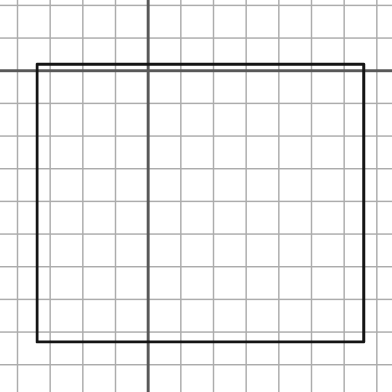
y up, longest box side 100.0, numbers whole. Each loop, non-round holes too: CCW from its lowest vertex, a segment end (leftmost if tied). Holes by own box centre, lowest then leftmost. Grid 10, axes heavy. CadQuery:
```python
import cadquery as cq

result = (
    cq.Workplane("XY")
    .moveTo(-34.0, -83.0)
    .lineTo(66.0, -83.0)
    .lineTo(66.0, 2.0)
    .lineTo(-34.0, 2.0)
    .close()
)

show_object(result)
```